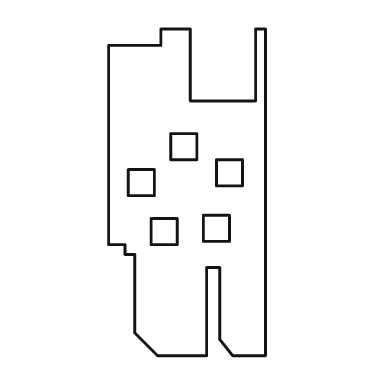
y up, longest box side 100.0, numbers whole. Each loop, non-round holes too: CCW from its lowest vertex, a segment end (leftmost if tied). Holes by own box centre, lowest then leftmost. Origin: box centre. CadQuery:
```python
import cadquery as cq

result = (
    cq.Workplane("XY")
    .moveTo(-9.0, -50.0)
    .lineTo(6.0, -50.0)
    .lineTo(6.0, -23.0)
    .lineTo(10.0, -23.0)
    .lineTo(10.0, -45.0)
    .lineTo(14.0, -50.0)
    .lineTo(24.0, -50.0)
    .lineTo(24.0, 50.0)
    .lineTo(21.0, 50.0)
    .lineTo(21.0, 28.0)
    .lineTo(1.0, 28.0)
    .lineTo(1.0, 50.0)
    .lineTo(-8.0, 50.0)
    .lineTo(-8.0, 45.0)
    .lineTo(-24.0, 45.0)
    .lineTo(-24.0, -16.0)
    .lineTo(-19.0, -16.0)
    .lineTo(-19.0, -19.0)
    .lineTo(-16.0, -19.0)
    .lineTo(-16.0, -43.0)
    .close()
    .moveTo(-11.0, -16.0)
    .lineTo(-3.0, -16.0)
    .lineTo(-3.0, -8.0)
    .lineTo(-11.0, -8.0)
    .close()
    .moveTo(5.0, -15.0)
    .lineTo(13.0, -15.0)
    .lineTo(13.0, -7.0)
    .lineTo(5.0, -7.0)
    .close()
    .moveTo(-18.0, -1.0)
    .lineTo(-10.0, -1.0)
    .lineTo(-10.0, 7.0)
    .lineTo(-18.0, 7.0)
    .close()
    .moveTo(9.0, 2.0)
    .lineTo(17.0, 2.0)
    .lineTo(17.0, 10.0)
    .lineTo(9.0, 10.0)
    .close()
    .moveTo(-5.0, 10.0)
    .lineTo(3.0, 10.0)
    .lineTo(3.0, 18.0)
    .lineTo(-5.0, 18.0)
    .close()
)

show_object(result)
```